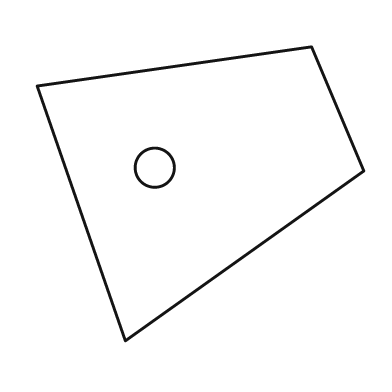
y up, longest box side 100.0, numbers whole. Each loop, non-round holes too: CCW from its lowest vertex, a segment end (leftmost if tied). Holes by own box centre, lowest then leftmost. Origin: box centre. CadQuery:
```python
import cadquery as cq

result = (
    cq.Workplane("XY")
    .moveTo(-23.0, -45.0)
    .lineTo(50.0, 7.0)
    .lineTo(34.0, 45.0)
    .lineTo(-50.0, 33.0)
    .close()
    .moveTo(-14.0, 8.0)
    .circle(6.0)
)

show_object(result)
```